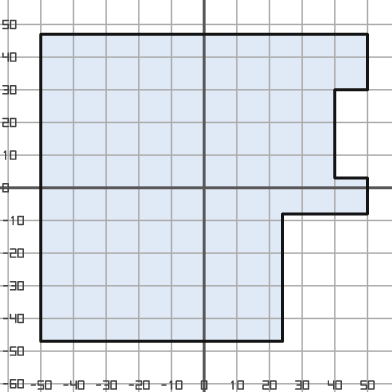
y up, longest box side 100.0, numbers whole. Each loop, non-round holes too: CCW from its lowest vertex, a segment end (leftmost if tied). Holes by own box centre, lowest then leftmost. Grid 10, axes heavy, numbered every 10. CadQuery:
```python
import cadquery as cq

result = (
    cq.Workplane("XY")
    .moveTo(-50.0, -47.0)
    .lineTo(24.0, -47.0)
    .lineTo(24.0, -8.0)
    .lineTo(50.0, -8.0)
    .lineTo(50.0, 3.0)
    .lineTo(40.0, 3.0)
    .lineTo(40.0, 30.0)
    .lineTo(50.0, 30.0)
    .lineTo(50.0, 47.0)
    .lineTo(-50.0, 47.0)
    .close()
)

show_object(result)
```